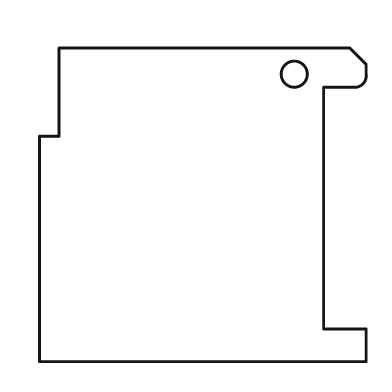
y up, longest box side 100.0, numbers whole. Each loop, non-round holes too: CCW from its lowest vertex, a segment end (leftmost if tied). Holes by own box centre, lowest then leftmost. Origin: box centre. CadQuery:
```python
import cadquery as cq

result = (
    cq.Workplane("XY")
    .moveTo(-50.0, -48.0)
    .lineTo(50.0, -48.0)
    .lineTo(50.0, -38.0)
    .lineTo(37.0, -38.0)
    .lineTo(37.0, 36.0)
    .lineTo(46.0, 36.0)
    .threePointArc((49.0, 37.0), (50.0, 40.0))
    .lineTo(50.0, 43.0)
    .lineTo(45.0, 48.0)
    .lineTo(-44.0, 48.0)
    .lineTo(-44.0, 21.0)
    .lineTo(-50.0, 21.0)
    .close()
    .moveTo(28.0, 40.0)
    .circle(4.0)
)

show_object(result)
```